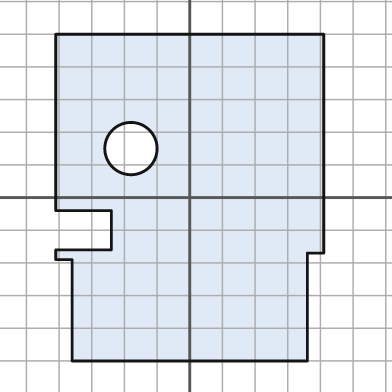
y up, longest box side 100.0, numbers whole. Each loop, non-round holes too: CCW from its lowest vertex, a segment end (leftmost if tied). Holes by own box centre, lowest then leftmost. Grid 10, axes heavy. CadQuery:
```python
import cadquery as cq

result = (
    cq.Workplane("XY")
    .moveTo(-36.0, -50.0)
    .lineTo(36.0, -50.0)
    .lineTo(36.0, -17.0)
    .lineTo(41.0, -17.0)
    .lineTo(41.0, 50.0)
    .lineTo(-41.0, 50.0)
    .lineTo(-41.0, -4.0)
    .lineTo(-24.0, -4.0)
    .lineTo(-24.0, -16.0)
    .lineTo(-41.0, -16.0)
    .lineTo(-41.0, -19.0)
    .lineTo(-36.0, -19.0)
    .close()
    .moveTo(-18.0, 15.0)
    .circle(8.0)
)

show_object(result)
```